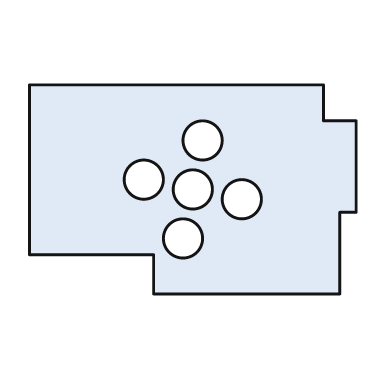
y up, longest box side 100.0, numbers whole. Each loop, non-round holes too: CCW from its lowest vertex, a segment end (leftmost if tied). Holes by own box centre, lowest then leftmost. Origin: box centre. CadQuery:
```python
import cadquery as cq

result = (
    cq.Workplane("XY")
    .moveTo(-12.0, -32.0)
    .lineTo(45.0, -32.0)
    .lineTo(45.0, -7.0)
    .lineTo(50.0, -7.0)
    .lineTo(50.0, 21.0)
    .lineTo(40.0, 21.0)
    .lineTo(40.0, 32.0)
    .lineTo(-50.0, 32.0)
    .lineTo(-50.0, -20.0)
    .lineTo(-12.0, -20.0)
    .close()
    .moveTo(-3.0, -15.0)
    .circle(6.0)
    .moveTo(15.0, -3.0)
    .circle(6.0)
    .moveTo(0.0, 0.0)
    .circle(6.0)
    .moveTo(-15.0, 3.0)
    .circle(6.0)
    .moveTo(3.0, 15.0)
    .circle(6.0)
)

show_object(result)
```